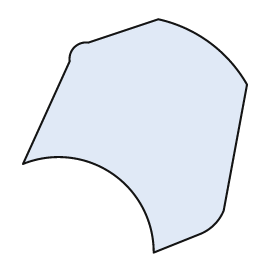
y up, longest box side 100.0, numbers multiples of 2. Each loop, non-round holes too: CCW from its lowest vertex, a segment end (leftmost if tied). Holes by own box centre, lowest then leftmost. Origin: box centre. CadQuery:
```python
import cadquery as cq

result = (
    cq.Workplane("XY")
    .moveTo(8.0, -50.0)
    .lineTo(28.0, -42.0)
    .threePointArc((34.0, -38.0), (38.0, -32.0))
    .lineTo(48.0, 22.0)
    .threePointArc((32.0, 40.0), (10.0, 50.0))
    .lineTo(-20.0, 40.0)
    .threePointArc((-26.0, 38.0), (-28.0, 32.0))
    .lineTo(-48.0, -12.0)
    .threePointArc((-10.0, -16.0), (8.0, -50.0))
    .close()
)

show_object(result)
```